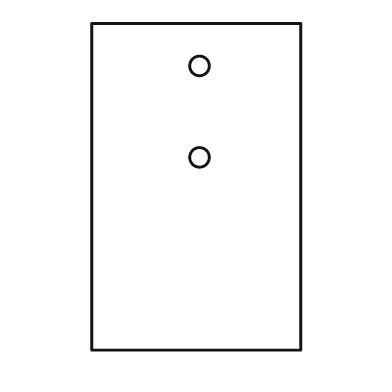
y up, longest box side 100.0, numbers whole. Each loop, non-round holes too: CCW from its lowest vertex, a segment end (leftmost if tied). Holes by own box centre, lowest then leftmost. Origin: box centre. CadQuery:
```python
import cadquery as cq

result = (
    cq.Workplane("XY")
    .moveTo(-32.0, -50.0)
    .lineTo(32.0, -50.0)
    .lineTo(32.0, 50.0)
    .lineTo(-32.0, 50.0)
    .close()
    .moveTo(1.0, 9.0)
    .circle(3.0)
    .moveTo(1.0, 37.0)
    .circle(3.0)
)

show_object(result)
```